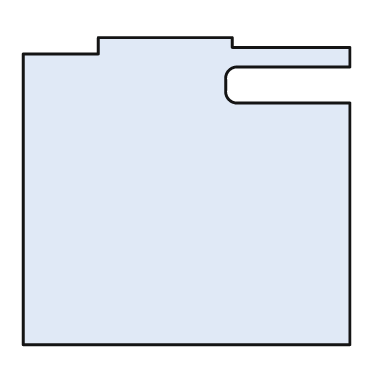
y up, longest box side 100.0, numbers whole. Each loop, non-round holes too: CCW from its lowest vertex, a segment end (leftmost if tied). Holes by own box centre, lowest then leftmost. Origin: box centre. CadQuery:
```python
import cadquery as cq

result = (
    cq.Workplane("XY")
    .moveTo(-50.0, -47.0)
    .lineTo(50.0, -47.0)
    .lineTo(50.0, 27.0)
    .lineTo(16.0, 27.0)
    .threePointArc((13.0, 28.0), (12.0, 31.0))
    .lineTo(12.0, 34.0)
    .threePointArc((13.0, 37.0), (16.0, 38.0))
    .lineTo(50.0, 38.0)
    .lineTo(50.0, 44.0)
    .lineTo(14.0, 44.0)
    .lineTo(14.0, 47.0)
    .lineTo(-27.0, 47.0)
    .lineTo(-27.0, 42.0)
    .lineTo(-50.0, 42.0)
    .close()
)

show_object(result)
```